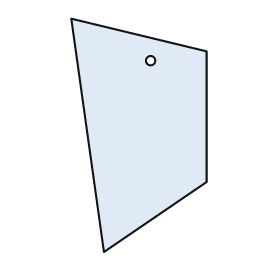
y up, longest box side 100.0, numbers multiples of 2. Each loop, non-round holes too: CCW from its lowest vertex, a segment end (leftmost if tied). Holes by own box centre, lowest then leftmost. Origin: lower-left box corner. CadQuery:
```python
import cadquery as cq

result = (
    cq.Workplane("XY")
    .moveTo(14.0, 0.0)
    .lineTo(58.0, 30.0)
    .lineTo(58.0, 86.0)
    .lineTo(0.0, 100.0)
    .close()
    .moveTo(34.0, 82.0)
    .circle(2.0)
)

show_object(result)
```